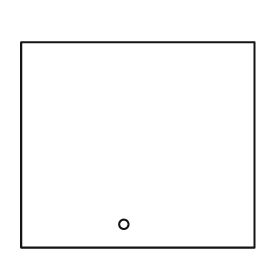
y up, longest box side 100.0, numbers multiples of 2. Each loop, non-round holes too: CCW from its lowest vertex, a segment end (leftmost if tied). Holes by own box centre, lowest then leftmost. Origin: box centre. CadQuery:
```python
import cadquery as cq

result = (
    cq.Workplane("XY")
    .moveTo(-50.0, -44.0)
    .lineTo(50.0, -44.0)
    .lineTo(50.0, 44.0)
    .lineTo(-50.0, 44.0)
    .close()
    .moveTo(-6.0, -34.0)
    .circle(2.0)
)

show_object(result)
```